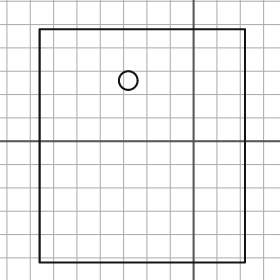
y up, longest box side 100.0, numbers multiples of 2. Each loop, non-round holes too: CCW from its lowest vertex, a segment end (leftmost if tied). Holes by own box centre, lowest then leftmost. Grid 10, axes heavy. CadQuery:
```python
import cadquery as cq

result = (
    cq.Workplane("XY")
    .moveTo(-66.0, -52.0)
    .lineTo(22.0, -52.0)
    .lineTo(22.0, 48.0)
    .lineTo(-66.0, 48.0)
    .close()
    .moveTo(-28.0, 26.0)
    .circle(4.0)
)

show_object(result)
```